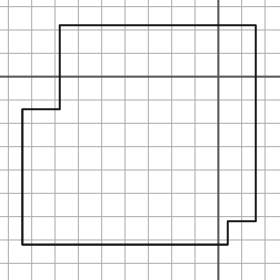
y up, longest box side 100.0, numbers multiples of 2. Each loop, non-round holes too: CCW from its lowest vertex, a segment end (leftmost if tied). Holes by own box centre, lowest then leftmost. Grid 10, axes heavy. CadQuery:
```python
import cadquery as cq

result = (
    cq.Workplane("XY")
    .moveTo(-84.0, -72.0)
    .lineTo(4.0, -72.0)
    .lineTo(4.0, -62.0)
    .lineTo(16.0, -62.0)
    .lineTo(16.0, 22.0)
    .lineTo(-68.0, 22.0)
    .lineTo(-68.0, -14.0)
    .lineTo(-84.0, -14.0)
    .close()
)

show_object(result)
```